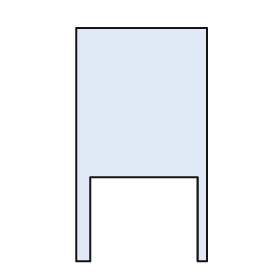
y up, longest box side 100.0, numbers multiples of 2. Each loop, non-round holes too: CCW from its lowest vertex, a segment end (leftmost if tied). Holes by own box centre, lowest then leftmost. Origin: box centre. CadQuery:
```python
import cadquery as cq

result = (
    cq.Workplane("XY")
    .moveTo(-28.0, -50.0)
    .lineTo(-22.0, -50.0)
    .lineTo(-22.0, -14.0)
    .lineTo(24.0, -14.0)
    .lineTo(24.0, -50.0)
    .lineTo(28.0, -50.0)
    .lineTo(28.0, 50.0)
    .lineTo(-28.0, 50.0)
    .close()
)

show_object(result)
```